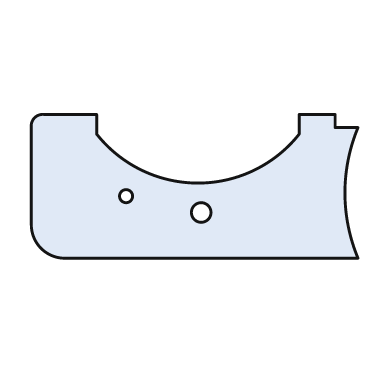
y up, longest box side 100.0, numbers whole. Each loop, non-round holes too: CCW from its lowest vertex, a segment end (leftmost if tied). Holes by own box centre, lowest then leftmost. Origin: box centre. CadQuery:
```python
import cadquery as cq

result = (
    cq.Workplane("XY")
    .moveTo(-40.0, -22.0)
    .lineTo(50.0, -22.0)
    .threePointArc((46.0, -2.0), (50.0, 18.0))
    .lineTo(43.0, 18.0)
    .lineTo(43.0, 22.0)
    .lineTo(32.0, 22.0)
    .lineTo(32.0, 16.0)
    .threePointArc((1.0, 1.0), (-30.0, 16.0))
    .lineTo(-30.0, 22.0)
    .lineTo(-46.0, 22.0)
    .threePointArc((-49.0, 21.0), (-50.0, 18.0))
    .lineTo(-50.0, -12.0)
    .threePointArc((-47.0, -19.0), (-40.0, -22.0))
    .close()
    .moveTo(2.0, -8.0)
    .circle(3.0)
    .moveTo(-21.0, -3.0)
    .circle(2.0)
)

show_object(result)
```